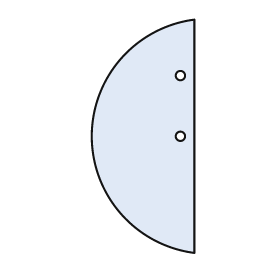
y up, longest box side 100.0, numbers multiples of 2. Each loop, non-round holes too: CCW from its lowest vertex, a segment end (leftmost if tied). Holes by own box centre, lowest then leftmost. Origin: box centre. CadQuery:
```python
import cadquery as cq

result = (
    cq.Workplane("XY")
    .moveTo(22.0, -50.0)
    .lineTo(22.0, 50.0)
    .threePointArc((-22.0, 0.0), (22.0, -50.0))
    .close()
    .moveTo(16.0, 0.0)
    .circle(2.0)
    .moveTo(16.0, 26.0)
    .circle(2.0)
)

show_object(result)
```